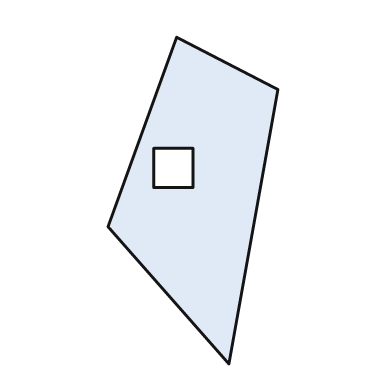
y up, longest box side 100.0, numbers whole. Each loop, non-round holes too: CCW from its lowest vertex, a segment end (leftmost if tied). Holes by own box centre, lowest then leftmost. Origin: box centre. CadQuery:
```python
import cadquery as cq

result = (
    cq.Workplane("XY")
    .moveTo(11.0, -50.0)
    .lineTo(26.0, 34.0)
    .lineTo(-5.0, 50.0)
    .lineTo(-26.0, -8.0)
    .close()
    .moveTo(-12.0, 4.0)
    .lineTo(0.0, 4.0)
    .lineTo(0.0, 16.0)
    .lineTo(-12.0, 16.0)
    .close()
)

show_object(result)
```